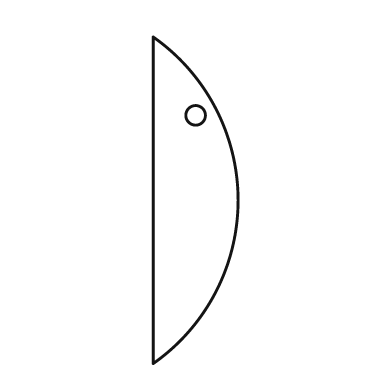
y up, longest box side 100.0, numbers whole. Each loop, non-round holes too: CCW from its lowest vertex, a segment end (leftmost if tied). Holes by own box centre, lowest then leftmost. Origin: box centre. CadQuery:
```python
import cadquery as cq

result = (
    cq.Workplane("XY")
    .moveTo(-13.0, -50.0)
    .threePointArc((13.0, 0.0), (-13.0, 50.0))
    .close()
    .moveTo(0.0, 26.0)
    .circle(3.0)
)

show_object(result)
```